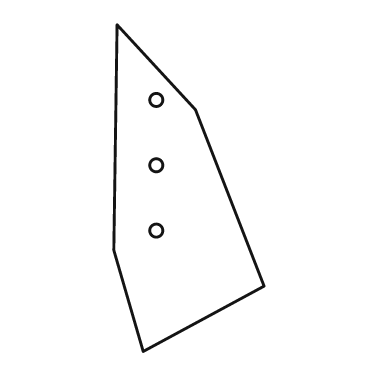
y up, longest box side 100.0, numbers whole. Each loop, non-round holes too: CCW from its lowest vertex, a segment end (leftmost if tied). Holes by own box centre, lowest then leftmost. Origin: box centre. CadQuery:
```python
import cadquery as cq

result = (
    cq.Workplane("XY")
    .moveTo(-14.0, -50.0)
    .lineTo(23.0, -30.0)
    .lineTo(2.0, 24.0)
    .lineTo(-22.0, 50.0)
    .lineTo(-23.0, -19.0)
    .close()
    .moveTo(-10.0, -13.0)
    .circle(2.0)
    .moveTo(-10.0, 7.0)
    .circle(2.0)
    .moveTo(-10.0, 27.0)
    .circle(2.0)
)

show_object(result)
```